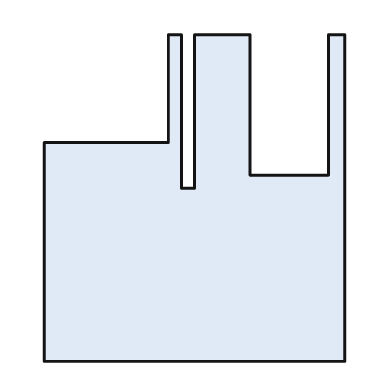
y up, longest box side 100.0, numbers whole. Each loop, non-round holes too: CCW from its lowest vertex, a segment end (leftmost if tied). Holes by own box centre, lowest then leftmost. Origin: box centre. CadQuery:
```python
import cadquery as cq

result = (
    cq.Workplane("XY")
    .moveTo(-46.0, -50.0)
    .lineTo(46.0, -50.0)
    .lineTo(46.0, 50.0)
    .lineTo(41.0, 50.0)
    .lineTo(41.0, 7.0)
    .lineTo(17.0, 7.0)
    .lineTo(17.0, 50.0)
    .lineTo(0.0, 50.0)
    .lineTo(0.0, 3.0)
    .lineTo(-4.0, 3.0)
    .lineTo(-4.0, 50.0)
    .lineTo(-8.0, 50.0)
    .lineTo(-8.0, 17.0)
    .lineTo(-46.0, 17.0)
    .close()
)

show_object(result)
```